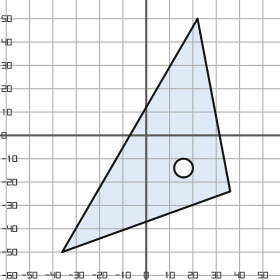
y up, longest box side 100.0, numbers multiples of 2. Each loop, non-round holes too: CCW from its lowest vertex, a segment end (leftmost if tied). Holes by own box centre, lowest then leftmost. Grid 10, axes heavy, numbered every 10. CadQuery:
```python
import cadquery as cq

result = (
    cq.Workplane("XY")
    .moveTo(-36.0, -50.0)
    .lineTo(36.0, -24.0)
    .lineTo(22.0, 50.0)
    .close()
    .moveTo(16.0, -14.0)
    .circle(4.0)
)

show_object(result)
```